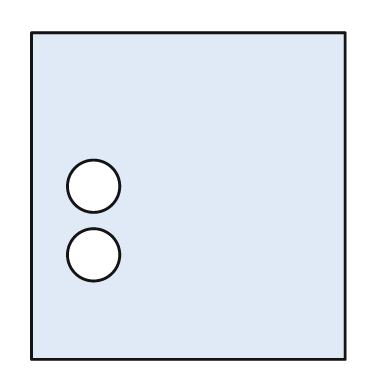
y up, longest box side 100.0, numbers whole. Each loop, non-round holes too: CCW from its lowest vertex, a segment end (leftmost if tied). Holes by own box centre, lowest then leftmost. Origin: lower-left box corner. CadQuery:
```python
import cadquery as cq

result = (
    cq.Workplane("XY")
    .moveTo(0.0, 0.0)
    .lineTo(96.0, 0.0)
    .lineTo(96.0, 100.0)
    .lineTo(0.0, 100.0)
    .close()
    .moveTo(19.0, 32.0)
    .circle(8.0)
    .moveTo(19.0, 53.0)
    .circle(8.0)
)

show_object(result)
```